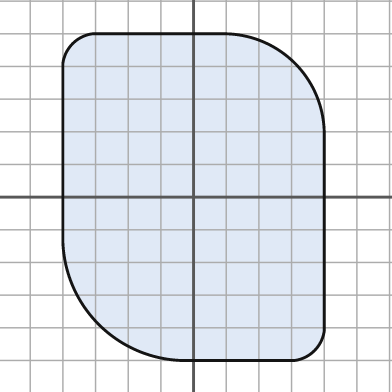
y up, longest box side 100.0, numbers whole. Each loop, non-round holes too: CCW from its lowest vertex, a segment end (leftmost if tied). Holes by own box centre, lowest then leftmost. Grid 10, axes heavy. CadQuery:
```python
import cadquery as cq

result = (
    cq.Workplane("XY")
    .moveTo(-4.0, -50.0)
    .lineTo(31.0, -50.0)
    .threePointArc((37.0, -47.0), (40.0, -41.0))
    .lineTo(40.0, 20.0)
    .threePointArc((31.0, 41.0), (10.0, 50.0))
    .lineTo(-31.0, 50.0)
    .threePointArc((-37.0, 47.0), (-40.0, 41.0))
    .lineTo(-40.0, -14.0)
    .threePointArc((-29.0, -39.0), (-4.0, -50.0))
    .close()
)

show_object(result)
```